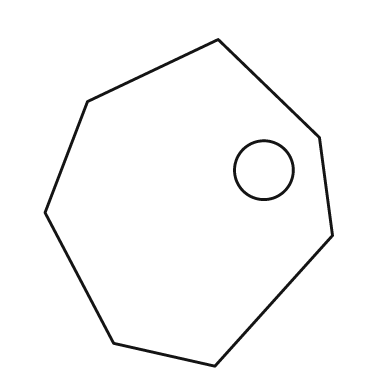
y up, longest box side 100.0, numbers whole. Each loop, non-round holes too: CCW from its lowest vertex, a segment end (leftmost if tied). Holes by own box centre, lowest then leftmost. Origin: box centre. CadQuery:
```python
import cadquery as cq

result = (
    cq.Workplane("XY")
    .moveTo(8.0, -50.0)
    .lineTo(44.0, -10.0)
    .lineTo(40.0, 20.0)
    .lineTo(9.0, 50.0)
    .lineTo(-31.0, 31.0)
    .lineTo(-44.0, -3.0)
    .lineTo(-23.0, -43.0)
    .close()
    .moveTo(23.0, 10.0)
    .circle(9.0)
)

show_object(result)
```